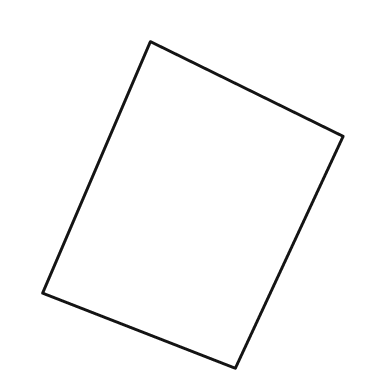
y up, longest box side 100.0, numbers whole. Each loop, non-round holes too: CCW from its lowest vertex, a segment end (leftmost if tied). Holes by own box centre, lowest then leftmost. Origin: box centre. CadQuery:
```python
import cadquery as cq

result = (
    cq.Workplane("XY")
    .moveTo(13.0, -50.0)
    .lineTo(46.0, 21.0)
    .lineTo(-13.0, 50.0)
    .lineTo(-46.0, -27.0)
    .close()
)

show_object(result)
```